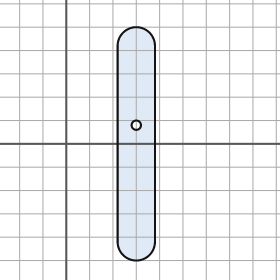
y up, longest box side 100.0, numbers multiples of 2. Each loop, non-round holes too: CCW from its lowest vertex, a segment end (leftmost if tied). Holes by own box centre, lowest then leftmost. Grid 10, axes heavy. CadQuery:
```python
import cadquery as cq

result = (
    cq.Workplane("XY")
    .moveTo(22.0, -42.0)
    .threePointArc((30.0, -50.0), (38.0, -42.0))
    .lineTo(38.0, 42.0)
    .threePointArc((30.0, 50.0), (22.0, 42.0))
    .close()
    .moveTo(30.0, 8.0)
    .circle(2.0)
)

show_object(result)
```